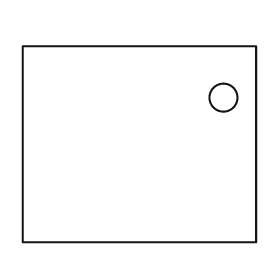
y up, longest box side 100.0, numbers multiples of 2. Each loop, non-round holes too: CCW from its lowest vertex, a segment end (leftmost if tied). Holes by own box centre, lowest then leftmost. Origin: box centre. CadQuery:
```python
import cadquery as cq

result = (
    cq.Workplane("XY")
    .moveTo(-50.0, -42.0)
    .lineTo(50.0, -42.0)
    .lineTo(50.0, 42.0)
    .lineTo(-50.0, 42.0)
    .close()
    .moveTo(36.0, 20.0)
    .circle(6.0)
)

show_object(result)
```